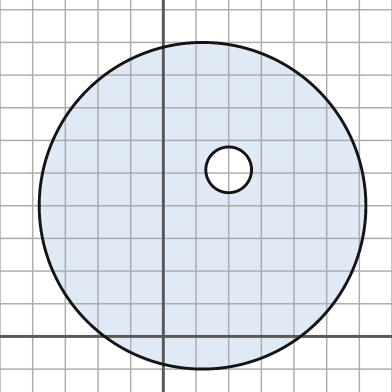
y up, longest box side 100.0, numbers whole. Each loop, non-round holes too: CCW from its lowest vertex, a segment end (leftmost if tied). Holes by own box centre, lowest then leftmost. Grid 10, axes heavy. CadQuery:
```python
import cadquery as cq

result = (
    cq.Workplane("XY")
    .moveTo(12.0, 40.0)
    .circle(50.0)
    .moveTo(20.0, 51.0)
    .circle(7.0)
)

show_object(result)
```